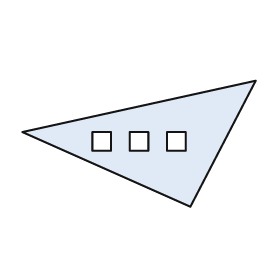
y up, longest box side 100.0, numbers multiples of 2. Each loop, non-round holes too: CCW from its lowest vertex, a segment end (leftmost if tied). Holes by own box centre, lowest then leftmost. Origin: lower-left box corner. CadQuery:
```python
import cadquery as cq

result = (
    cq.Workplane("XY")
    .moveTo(72.0, 0.0)
    .lineTo(100.0, 54.0)
    .lineTo(0.0, 32.0)
    .close()
    .moveTo(30.0, 24.0)
    .lineTo(38.0, 24.0)
    .lineTo(38.0, 32.0)
    .lineTo(30.0, 32.0)
    .close()
    .moveTo(46.0, 24.0)
    .lineTo(54.0, 24.0)
    .lineTo(54.0, 32.0)
    .lineTo(46.0, 32.0)
    .close()
    .moveTo(62.0, 24.0)
    .lineTo(70.0, 24.0)
    .lineTo(70.0, 32.0)
    .lineTo(62.0, 32.0)
    .close()
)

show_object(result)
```